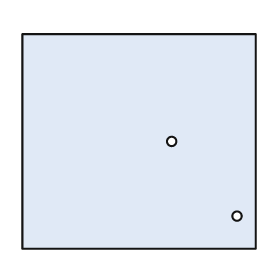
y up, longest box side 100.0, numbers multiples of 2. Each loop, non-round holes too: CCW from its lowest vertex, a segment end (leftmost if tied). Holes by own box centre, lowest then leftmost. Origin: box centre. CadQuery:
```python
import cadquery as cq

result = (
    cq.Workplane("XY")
    .moveTo(-50.0, -46.0)
    .lineTo(50.0, -46.0)
    .lineTo(50.0, 46.0)
    .lineTo(-50.0, 46.0)
    .close()
    .moveTo(42.0, -32.0)
    .circle(2.0)
    .moveTo(14.0, 0.0)
    .circle(2.0)
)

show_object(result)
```